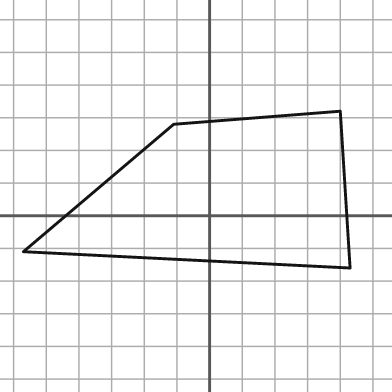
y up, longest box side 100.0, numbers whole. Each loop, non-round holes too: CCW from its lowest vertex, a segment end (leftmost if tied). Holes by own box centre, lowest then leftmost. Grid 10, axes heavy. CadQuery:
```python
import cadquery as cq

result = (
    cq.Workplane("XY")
    .moveTo(43.0, -16.0)
    .lineTo(40.0, 32.0)
    .lineTo(-11.0, 28.0)
    .lineTo(-57.0, -11.0)
    .close()
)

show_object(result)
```